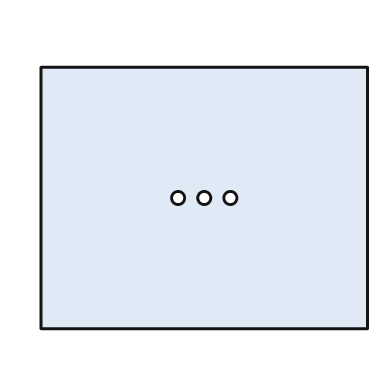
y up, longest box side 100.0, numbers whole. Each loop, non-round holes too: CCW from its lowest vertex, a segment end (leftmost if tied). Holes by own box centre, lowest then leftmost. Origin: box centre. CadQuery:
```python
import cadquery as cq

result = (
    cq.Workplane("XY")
    .moveTo(-50.0, -40.0)
    .lineTo(50.0, -40.0)
    .lineTo(50.0, 40.0)
    .lineTo(-50.0, 40.0)
    .close()
    .moveTo(-8.0, 0.0)
    .circle(2.0)
    .moveTo(0.0, 0.0)
    .circle(2.0)
    .moveTo(8.0, 0.0)
    .circle(2.0)
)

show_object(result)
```